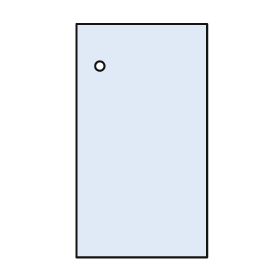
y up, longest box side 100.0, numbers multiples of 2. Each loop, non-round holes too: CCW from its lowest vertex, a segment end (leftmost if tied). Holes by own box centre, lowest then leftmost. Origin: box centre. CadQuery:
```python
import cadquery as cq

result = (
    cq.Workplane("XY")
    .moveTo(-28.0, -50.0)
    .lineTo(28.0, -50.0)
    .lineTo(28.0, 50.0)
    .lineTo(-28.0, 50.0)
    .close()
    .moveTo(-18.0, 32.0)
    .circle(2.0)
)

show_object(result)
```